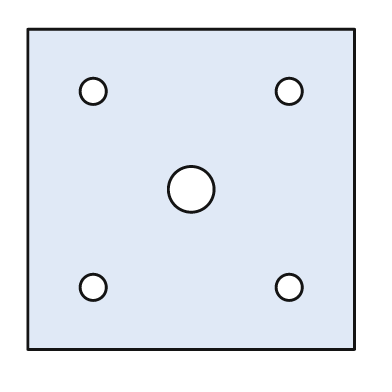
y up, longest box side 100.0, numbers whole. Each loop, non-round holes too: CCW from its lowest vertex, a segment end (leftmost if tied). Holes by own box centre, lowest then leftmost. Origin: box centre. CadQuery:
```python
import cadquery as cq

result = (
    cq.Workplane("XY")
    .moveTo(-50.0, -49.0)
    .lineTo(50.0, -49.0)
    .lineTo(50.0, 49.0)
    .lineTo(-50.0, 49.0)
    .close()
    .moveTo(-30.0, -30.0)
    .circle(4.0)
    .moveTo(30.0, -30.0)
    .circle(4.0)
    .moveTo(0.0, 0.0)
    .circle(7.0)
    .moveTo(-30.0, 30.0)
    .circle(4.0)
    .moveTo(30.0, 30.0)
    .circle(4.0)
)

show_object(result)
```